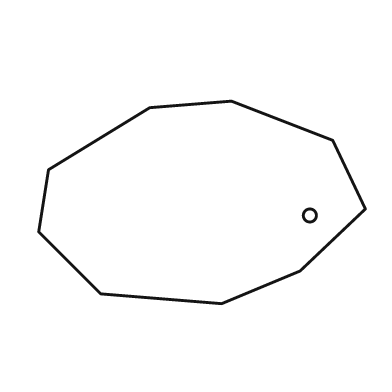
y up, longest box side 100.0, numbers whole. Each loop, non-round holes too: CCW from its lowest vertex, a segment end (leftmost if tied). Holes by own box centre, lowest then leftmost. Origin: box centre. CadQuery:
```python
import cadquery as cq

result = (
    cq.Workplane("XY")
    .moveTo(6.0, -31.0)
    .lineTo(30.0, -21.0)
    .lineTo(50.0, -2.0)
    .lineTo(40.0, 19.0)
    .lineTo(9.0, 31.0)
    .lineTo(-16.0, 29.0)
    .lineTo(-47.0, 10.0)
    .lineTo(-50.0, -9.0)
    .lineTo(-31.0, -28.0)
    .close()
    .moveTo(33.0, -4.0)
    .circle(2.0)
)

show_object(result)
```